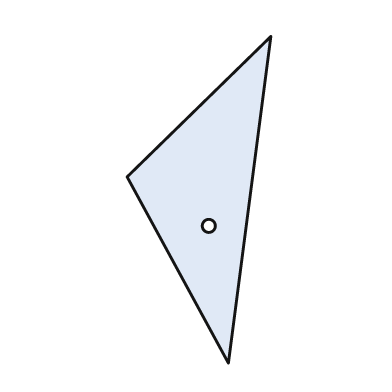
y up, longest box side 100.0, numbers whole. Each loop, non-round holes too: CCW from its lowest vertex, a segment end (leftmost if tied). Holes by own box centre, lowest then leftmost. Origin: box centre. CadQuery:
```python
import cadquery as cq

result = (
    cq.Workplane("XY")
    .moveTo(9.0, -50.0)
    .lineTo(22.0, 50.0)
    .lineTo(-22.0, 7.0)
    .close()
    .moveTo(3.0, -8.0)
    .circle(2.0)
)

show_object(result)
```